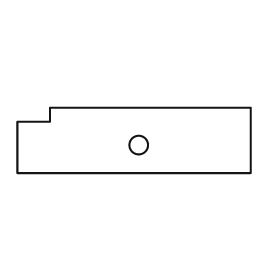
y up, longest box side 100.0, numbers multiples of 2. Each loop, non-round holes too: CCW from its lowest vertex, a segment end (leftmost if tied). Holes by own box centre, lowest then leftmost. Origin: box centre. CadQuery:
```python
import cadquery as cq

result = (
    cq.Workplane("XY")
    .moveTo(-50.0, -14.0)
    .lineTo(50.0, -14.0)
    .lineTo(50.0, 14.0)
    .lineTo(-36.0, 14.0)
    .lineTo(-36.0, 8.0)
    .lineTo(-50.0, 8.0)
    .close()
    .moveTo(2.0, -2.0)
    .circle(4.0)
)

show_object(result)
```